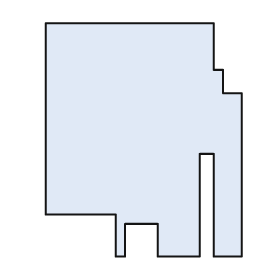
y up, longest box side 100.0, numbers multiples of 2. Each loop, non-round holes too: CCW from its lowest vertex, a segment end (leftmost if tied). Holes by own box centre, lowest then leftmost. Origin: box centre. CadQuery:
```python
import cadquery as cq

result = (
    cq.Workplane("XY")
    .moveTo(-12.0, -50.0)
    .lineTo(-8.0, -50.0)
    .lineTo(-8.0, -36.0)
    .lineTo(6.0, -36.0)
    .lineTo(6.0, -50.0)
    .lineTo(24.0, -50.0)
    .lineTo(24.0, -6.0)
    .lineTo(30.0, -6.0)
    .lineTo(30.0, -50.0)
    .lineTo(42.0, -50.0)
    .lineTo(42.0, 20.0)
    .lineTo(34.0, 20.0)
    .lineTo(34.0, 30.0)
    .lineTo(30.0, 30.0)
    .lineTo(30.0, 50.0)
    .lineTo(-42.0, 50.0)
    .lineTo(-42.0, -32.0)
    .lineTo(-12.0, -32.0)
    .close()
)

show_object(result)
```